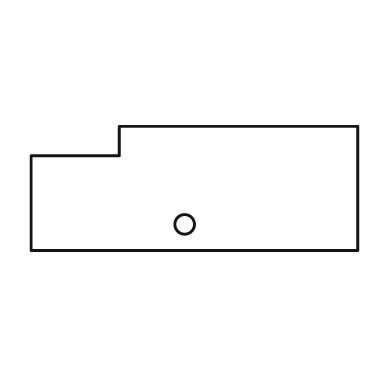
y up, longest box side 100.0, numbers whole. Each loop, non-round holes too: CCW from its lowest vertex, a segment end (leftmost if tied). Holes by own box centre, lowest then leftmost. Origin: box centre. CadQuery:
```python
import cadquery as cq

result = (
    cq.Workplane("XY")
    .moveTo(-50.0, -19.0)
    .lineTo(50.0, -19.0)
    .lineTo(50.0, 19.0)
    .lineTo(-23.0, 19.0)
    .lineTo(-23.0, 10.0)
    .lineTo(-50.0, 10.0)
    .close()
    .moveTo(-3.0, -11.0)
    .circle(3.0)
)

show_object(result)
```